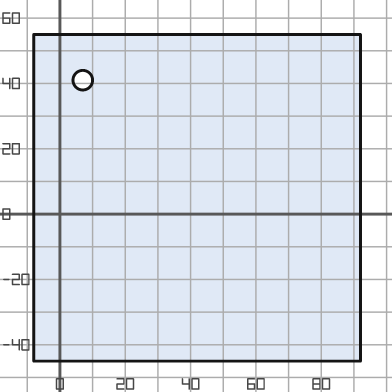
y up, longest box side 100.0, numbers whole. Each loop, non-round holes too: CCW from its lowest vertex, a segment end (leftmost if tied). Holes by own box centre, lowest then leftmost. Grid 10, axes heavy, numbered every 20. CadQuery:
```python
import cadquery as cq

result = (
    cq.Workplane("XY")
    .moveTo(-8.0, -45.0)
    .lineTo(92.0, -45.0)
    .lineTo(92.0, 55.0)
    .lineTo(-8.0, 55.0)
    .close()
    .moveTo(7.0, 41.0)
    .circle(3.0)
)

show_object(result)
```